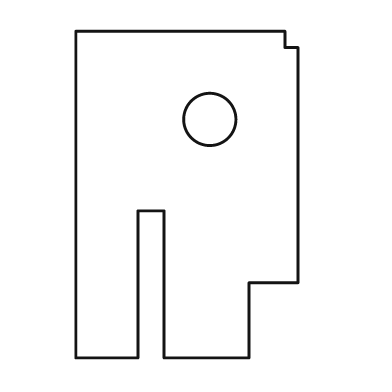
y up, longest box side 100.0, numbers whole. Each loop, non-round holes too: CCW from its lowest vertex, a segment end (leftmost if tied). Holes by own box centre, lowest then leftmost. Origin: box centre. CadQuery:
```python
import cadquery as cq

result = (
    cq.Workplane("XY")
    .moveTo(-34.0, -50.0)
    .lineTo(-15.0, -50.0)
    .lineTo(-15.0, -5.0)
    .lineTo(-7.0, -5.0)
    .lineTo(-7.0, -50.0)
    .lineTo(19.0, -50.0)
    .lineTo(19.0, -27.0)
    .lineTo(34.0, -27.0)
    .lineTo(34.0, 45.0)
    .lineTo(30.0, 45.0)
    .lineTo(30.0, 50.0)
    .lineTo(-34.0, 50.0)
    .close()
    .moveTo(7.0, 23.0)
    .circle(8.0)
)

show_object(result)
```